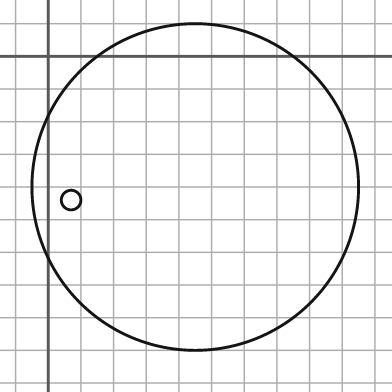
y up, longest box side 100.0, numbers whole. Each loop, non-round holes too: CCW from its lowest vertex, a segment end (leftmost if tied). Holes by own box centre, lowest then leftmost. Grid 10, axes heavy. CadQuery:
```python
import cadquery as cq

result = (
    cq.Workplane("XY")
    .moveTo(45.0, -40.0)
    .circle(50.0)
    .moveTo(7.0, -44.0)
    .circle(3.0)
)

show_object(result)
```